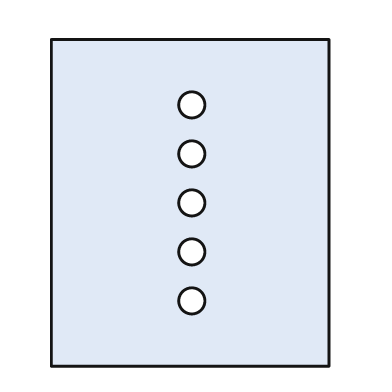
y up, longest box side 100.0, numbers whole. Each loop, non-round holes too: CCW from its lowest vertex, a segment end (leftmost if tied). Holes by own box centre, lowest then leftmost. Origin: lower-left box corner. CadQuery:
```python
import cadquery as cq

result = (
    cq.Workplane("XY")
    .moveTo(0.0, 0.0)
    .lineTo(85.0, 0.0)
    .lineTo(85.0, 100.0)
    .lineTo(0.0, 100.0)
    .close()
    .moveTo(43.0, 20.0)
    .circle(4.0)
    .moveTo(43.0, 35.0)
    .circle(4.0)
    .moveTo(43.0, 50.0)
    .circle(4.0)
    .moveTo(43.0, 65.0)
    .circle(4.0)
    .moveTo(43.0, 80.0)
    .circle(4.0)
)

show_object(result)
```